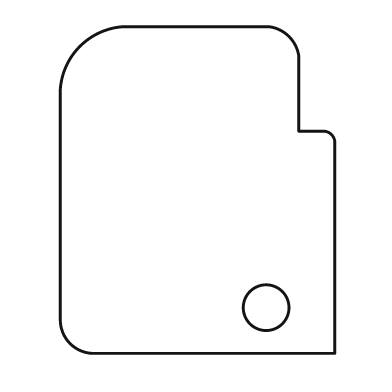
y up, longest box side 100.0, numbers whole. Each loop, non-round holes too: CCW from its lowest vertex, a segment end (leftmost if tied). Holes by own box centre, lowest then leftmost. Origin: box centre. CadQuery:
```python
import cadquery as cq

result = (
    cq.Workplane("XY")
    .moveTo(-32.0, -50.0)
    .lineTo(42.0, -50.0)
    .lineTo(42.0, 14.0)
    .threePointArc((41.0, 17.0), (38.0, 18.0))
    .lineTo(31.0, 18.0)
    .lineTo(31.0, 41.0)
    .threePointArc((28.0, 47.0), (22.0, 50.0))
    .lineTo(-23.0, 50.0)
    .threePointArc((-36.0, 44.0), (-42.0, 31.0))
    .lineTo(-42.0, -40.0)
    .threePointArc((-39.0, -47.0), (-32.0, -50.0))
    .close()
    .moveTo(21.0, -36.0)
    .circle(7.0)
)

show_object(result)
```